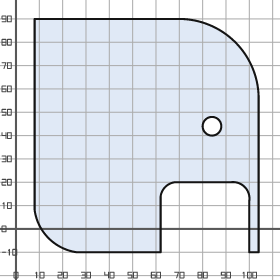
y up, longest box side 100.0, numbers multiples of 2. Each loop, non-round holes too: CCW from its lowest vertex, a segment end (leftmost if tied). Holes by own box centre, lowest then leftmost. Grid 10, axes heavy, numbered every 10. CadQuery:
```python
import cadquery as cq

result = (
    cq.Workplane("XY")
    .moveTo(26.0, -10.0)
    .lineTo(62.0, -10.0)
    .lineTo(62.0, 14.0)
    .threePointArc((64.0, 18.0), (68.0, 20.0))
    .lineTo(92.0, 20.0)
    .threePointArc((98.0, 18.0), (100.0, 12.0))
    .lineTo(100.0, -10.0)
    .lineTo(104.0, -10.0)
    .lineTo(104.0, 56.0)
    .threePointArc((94.0, 80.0), (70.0, 90.0))
    .lineTo(8.0, 90.0)
    .lineTo(8.0, 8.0)
    .threePointArc((14.0, -4.0), (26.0, -10.0))
    .close()
    .moveTo(84.0, 44.0)
    .circle(4.0)
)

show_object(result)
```